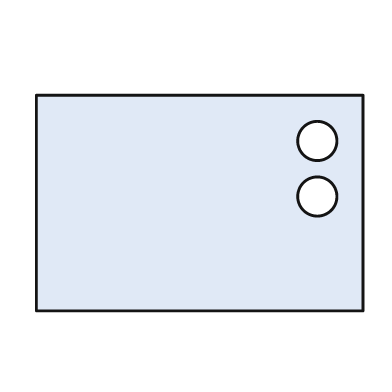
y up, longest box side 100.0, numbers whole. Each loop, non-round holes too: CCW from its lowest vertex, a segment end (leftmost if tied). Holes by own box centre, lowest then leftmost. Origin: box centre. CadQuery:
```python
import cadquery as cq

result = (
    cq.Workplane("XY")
    .moveTo(-50.0, -33.0)
    .lineTo(50.0, -33.0)
    .lineTo(50.0, 33.0)
    .lineTo(-50.0, 33.0)
    .close()
    .moveTo(36.0, 2.0)
    .circle(6.0)
    .moveTo(36.0, 19.0)
    .circle(6.0)
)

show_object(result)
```